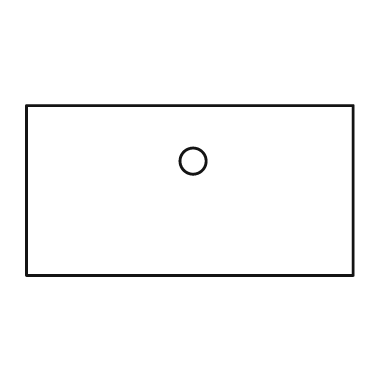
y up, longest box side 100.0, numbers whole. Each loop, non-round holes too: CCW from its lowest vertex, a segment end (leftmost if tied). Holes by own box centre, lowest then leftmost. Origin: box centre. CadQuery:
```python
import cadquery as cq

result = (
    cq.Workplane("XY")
    .moveTo(-50.0, -26.0)
    .lineTo(50.0, -26.0)
    .lineTo(50.0, 26.0)
    .lineTo(-50.0, 26.0)
    .close()
    .moveTo(1.0, 9.0)
    .circle(4.0)
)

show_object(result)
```